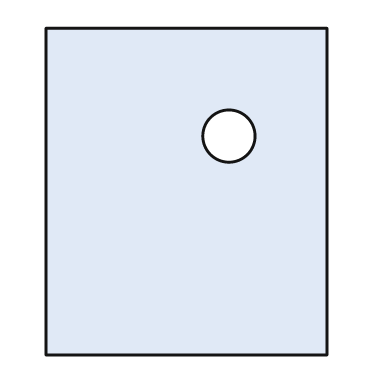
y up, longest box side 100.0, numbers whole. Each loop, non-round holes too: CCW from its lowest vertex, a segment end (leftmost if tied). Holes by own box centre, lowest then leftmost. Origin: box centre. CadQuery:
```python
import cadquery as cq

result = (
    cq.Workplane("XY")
    .moveTo(-43.0, -50.0)
    .lineTo(43.0, -50.0)
    .lineTo(43.0, 50.0)
    .lineTo(-43.0, 50.0)
    .close()
    .moveTo(13.0, 17.0)
    .circle(8.0)
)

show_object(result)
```